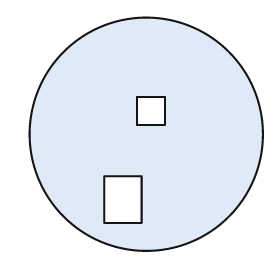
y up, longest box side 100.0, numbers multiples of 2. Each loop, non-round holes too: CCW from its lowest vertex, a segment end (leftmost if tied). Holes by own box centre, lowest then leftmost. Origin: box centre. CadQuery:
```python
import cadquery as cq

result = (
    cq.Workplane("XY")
    .moveTo(0.0, 0.0)
    .circle(50.0)
    .moveTo(-18.0, -38.0)
    .lineTo(-2.0, -38.0)
    .lineTo(-2.0, -18.0)
    .lineTo(-18.0, -18.0)
    .close()
    .moveTo(-4.0, 4.0)
    .lineTo(8.0, 4.0)
    .lineTo(8.0, 16.0)
    .lineTo(-4.0, 16.0)
    .close()
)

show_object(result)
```